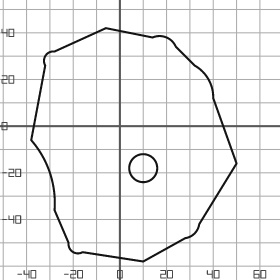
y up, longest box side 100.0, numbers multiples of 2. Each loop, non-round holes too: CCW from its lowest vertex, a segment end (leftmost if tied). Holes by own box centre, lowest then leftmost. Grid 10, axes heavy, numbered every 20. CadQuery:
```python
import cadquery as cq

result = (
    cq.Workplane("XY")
    .moveTo(10.0, -58.0)
    .lineTo(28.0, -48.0)
    .threePointArc((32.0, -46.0), (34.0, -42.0))
    .lineTo(50.0, -16.0)
    .lineTo(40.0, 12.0)
    .threePointArc((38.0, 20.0), (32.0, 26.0))
    .lineTo(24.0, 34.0)
    .threePointArc((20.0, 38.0), (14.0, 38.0))
    .lineTo(-6.0, 42.0)
    .lineTo(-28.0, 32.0)
    .threePointArc((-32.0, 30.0), (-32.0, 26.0))
    .lineTo(-38.0, -6.0)
    .threePointArc((-30.0, -20.0), (-28.0, -36.0))
    .lineTo(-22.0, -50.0)
    .threePointArc((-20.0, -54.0), (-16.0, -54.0))
    .close()
    .moveTo(10.0, -18.0)
    .circle(6.0)
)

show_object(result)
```